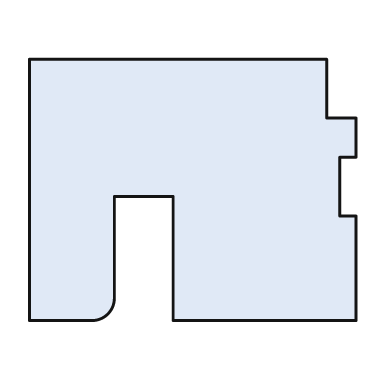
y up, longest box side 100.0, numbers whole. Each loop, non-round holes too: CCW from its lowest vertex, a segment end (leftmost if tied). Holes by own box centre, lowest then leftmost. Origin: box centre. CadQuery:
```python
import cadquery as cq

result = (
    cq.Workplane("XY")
    .moveTo(-50.0, -40.0)
    .lineTo(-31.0, -40.0)
    .threePointArc((-26.0, -38.0), (-24.0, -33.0))
    .lineTo(-24.0, -2.0)
    .lineTo(-6.0, -2.0)
    .lineTo(-6.0, -40.0)
    .lineTo(50.0, -40.0)
    .lineTo(50.0, -8.0)
    .lineTo(45.0, -8.0)
    .lineTo(45.0, 10.0)
    .lineTo(50.0, 10.0)
    .lineTo(50.0, 22.0)
    .lineTo(41.0, 22.0)
    .lineTo(41.0, 40.0)
    .lineTo(-50.0, 40.0)
    .close()
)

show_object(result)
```